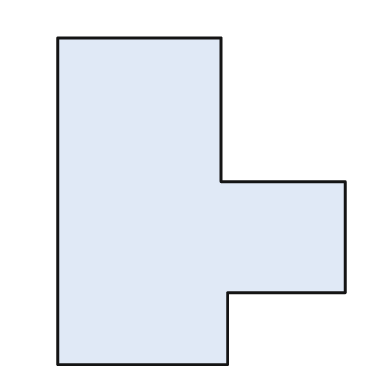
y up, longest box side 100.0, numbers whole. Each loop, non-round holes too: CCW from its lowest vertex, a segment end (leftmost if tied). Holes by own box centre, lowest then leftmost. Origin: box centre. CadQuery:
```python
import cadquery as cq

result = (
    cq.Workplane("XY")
    .moveTo(-44.0, -50.0)
    .lineTo(8.0, -50.0)
    .lineTo(8.0, -28.0)
    .lineTo(44.0, -28.0)
    .lineTo(44.0, 6.0)
    .lineTo(6.0, 6.0)
    .lineTo(6.0, 50.0)
    .lineTo(-44.0, 50.0)
    .close()
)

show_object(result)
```